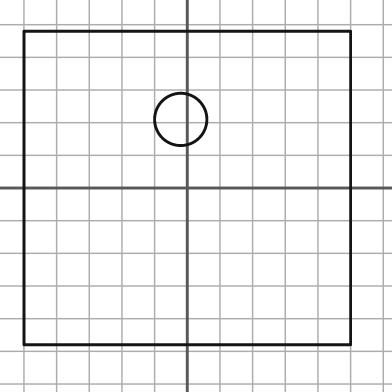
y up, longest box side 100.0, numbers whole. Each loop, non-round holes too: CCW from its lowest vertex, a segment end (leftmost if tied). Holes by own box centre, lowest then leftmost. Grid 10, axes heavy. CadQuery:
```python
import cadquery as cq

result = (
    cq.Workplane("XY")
    .moveTo(-50.0, -48.0)
    .lineTo(50.0, -48.0)
    .lineTo(50.0, 48.0)
    .lineTo(-50.0, 48.0)
    .close()
    .moveTo(-2.0, 21.0)
    .circle(8.0)
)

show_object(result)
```